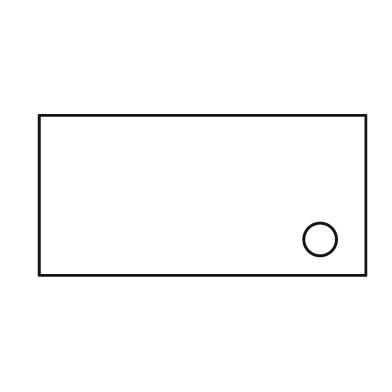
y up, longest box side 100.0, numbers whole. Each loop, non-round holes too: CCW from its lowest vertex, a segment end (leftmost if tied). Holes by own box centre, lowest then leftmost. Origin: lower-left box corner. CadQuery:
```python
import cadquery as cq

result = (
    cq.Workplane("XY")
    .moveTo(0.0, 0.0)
    .lineTo(100.0, 0.0)
    .lineTo(100.0, 49.0)
    .lineTo(0.0, 49.0)
    .close()
    .moveTo(86.0, 11.0)
    .circle(5.0)
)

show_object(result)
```